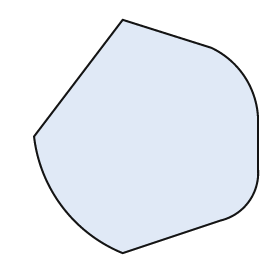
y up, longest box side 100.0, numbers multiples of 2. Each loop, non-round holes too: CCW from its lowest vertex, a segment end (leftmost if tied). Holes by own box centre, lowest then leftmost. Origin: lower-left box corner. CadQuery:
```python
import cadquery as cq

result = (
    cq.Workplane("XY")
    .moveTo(38.0, 0.0)
    .lineTo(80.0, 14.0)
    .threePointArc((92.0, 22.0), (96.0, 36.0))
    .lineTo(96.0, 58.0)
    .threePointArc((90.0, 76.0), (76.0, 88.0))
    .lineTo(38.0, 100.0)
    .lineTo(0.0, 50.0)
    .threePointArc((12.0, 20.0), (38.0, 0.0))
    .close()
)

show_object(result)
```